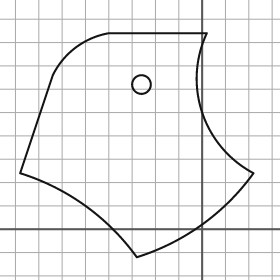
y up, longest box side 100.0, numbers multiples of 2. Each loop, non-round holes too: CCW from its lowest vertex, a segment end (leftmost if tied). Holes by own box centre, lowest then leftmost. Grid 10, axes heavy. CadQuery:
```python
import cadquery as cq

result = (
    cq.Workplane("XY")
    .moveTo(-28.0, -12.0)
    .threePointArc((0.0, 2.0), (22.0, 24.0))
    .threePointArc((0.0, 50.0), (2.0, 84.0))
    .lineTo(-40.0, 84.0)
    .threePointArc((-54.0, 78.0), (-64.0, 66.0))
    .lineTo(-78.0, 24.0)
    .threePointArc((-50.0, 10.0), (-28.0, -12.0))
    .close()
    .moveTo(-26.0, 62.0)
    .circle(4.0)
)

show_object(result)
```